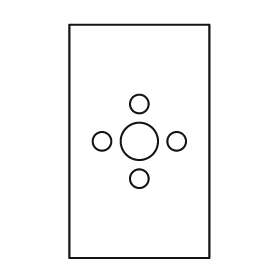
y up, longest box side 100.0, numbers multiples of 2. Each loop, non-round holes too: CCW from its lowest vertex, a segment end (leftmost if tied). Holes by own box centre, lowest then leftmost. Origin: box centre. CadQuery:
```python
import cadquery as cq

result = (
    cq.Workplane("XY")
    .moveTo(-30.0, -50.0)
    .lineTo(30.0, -50.0)
    .lineTo(30.0, 50.0)
    .lineTo(-30.0, 50.0)
    .close()
    .moveTo(0.0, -16.0)
    .circle(4.0)
    .moveTo(-16.0, 0.0)
    .circle(4.0)
    .moveTo(0.0, 0.0)
    .circle(8.0)
    .moveTo(16.0, 0.0)
    .circle(4.0)
    .moveTo(0.0, 16.0)
    .circle(4.0)
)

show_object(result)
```